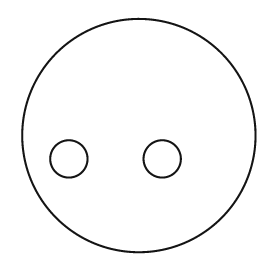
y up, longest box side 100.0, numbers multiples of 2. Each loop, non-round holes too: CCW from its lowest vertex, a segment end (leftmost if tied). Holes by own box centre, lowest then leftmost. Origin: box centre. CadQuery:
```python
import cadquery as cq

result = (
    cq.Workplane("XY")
    .moveTo(0.0, 0.0)
    .circle(50.0)
    .moveTo(-30.0, -10.0)
    .circle(8.0)
    .moveTo(10.0, -10.0)
    .circle(8.0)
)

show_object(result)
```